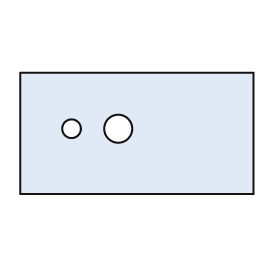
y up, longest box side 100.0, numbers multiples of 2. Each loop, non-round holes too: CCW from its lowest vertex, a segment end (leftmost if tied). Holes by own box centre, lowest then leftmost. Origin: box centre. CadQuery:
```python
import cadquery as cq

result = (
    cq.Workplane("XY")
    .moveTo(-50.0, -26.0)
    .lineTo(50.0, -26.0)
    .lineTo(50.0, 26.0)
    .lineTo(-50.0, 26.0)
    .close()
    .moveTo(-28.0, 2.0)
    .circle(4.0)
    .moveTo(-8.0, 2.0)
    .circle(6.0)
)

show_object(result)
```